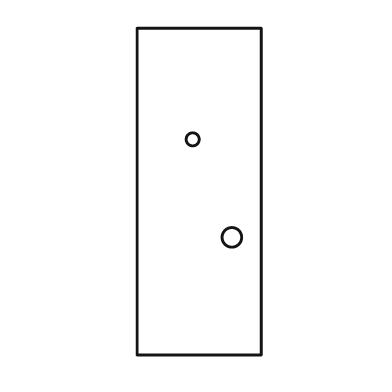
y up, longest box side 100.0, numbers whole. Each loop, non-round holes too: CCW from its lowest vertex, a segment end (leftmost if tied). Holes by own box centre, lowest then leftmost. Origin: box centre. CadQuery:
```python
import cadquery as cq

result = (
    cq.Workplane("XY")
    .moveTo(-19.0, -50.0)
    .lineTo(19.0, -50.0)
    .lineTo(19.0, 50.0)
    .lineTo(-19.0, 50.0)
    .close()
    .moveTo(10.0, -14.0)
    .circle(3.0)
    .moveTo(-2.0, 16.0)
    .circle(2.0)
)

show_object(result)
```